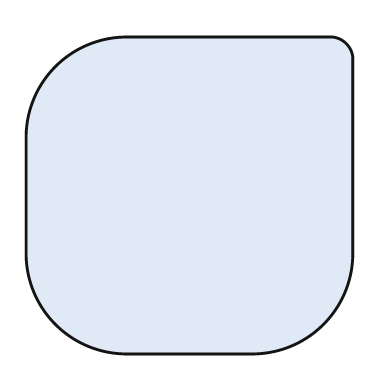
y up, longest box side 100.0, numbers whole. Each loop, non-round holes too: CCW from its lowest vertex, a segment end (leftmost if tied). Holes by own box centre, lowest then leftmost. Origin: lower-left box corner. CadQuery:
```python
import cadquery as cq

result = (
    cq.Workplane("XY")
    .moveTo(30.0, 0.0)
    .lineTo(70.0, 0.0)
    .threePointArc((91.0, 9.0), (100.0, 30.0))
    .lineTo(100.0, 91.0)
    .threePointArc((98.0, 95.0), (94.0, 97.0))
    .lineTo(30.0, 97.0)
    .threePointArc((9.0, 88.0), (0.0, 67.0))
    .lineTo(0.0, 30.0)
    .threePointArc((9.0, 9.0), (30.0, 0.0))
    .close()
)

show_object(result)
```